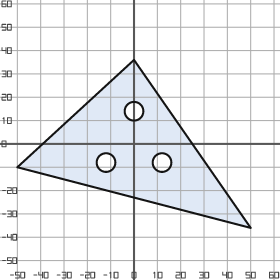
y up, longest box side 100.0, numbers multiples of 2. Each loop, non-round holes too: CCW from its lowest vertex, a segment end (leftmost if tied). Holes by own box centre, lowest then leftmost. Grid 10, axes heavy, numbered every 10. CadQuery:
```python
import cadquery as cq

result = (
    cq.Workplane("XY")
    .moveTo(50.0, -36.0)
    .lineTo(0.0, 36.0)
    .lineTo(-50.0, -10.0)
    .close()
    .moveTo(-12.0, -8.0)
    .circle(4.0)
    .moveTo(12.0, -8.0)
    .circle(4.0)
    .moveTo(0.0, 14.0)
    .circle(4.0)
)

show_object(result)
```